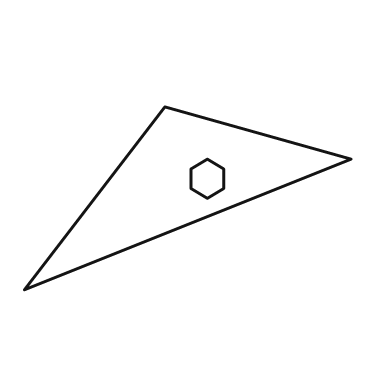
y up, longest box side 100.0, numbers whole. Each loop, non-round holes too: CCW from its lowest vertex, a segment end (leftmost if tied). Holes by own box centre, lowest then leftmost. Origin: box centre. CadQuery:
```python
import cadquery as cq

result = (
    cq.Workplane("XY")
    .moveTo(-50.0, -28.0)
    .lineTo(50.0, 12.0)
    .lineTo(-7.0, 28.0)
    .close()
    .moveTo(6.0, 0.0)
    .lineTo(11.0, 3.0)
    .lineTo(11.0, 9.0)
    .lineTo(6.0, 12.0)
    .lineTo(1.0, 9.0)
    .lineTo(1.0, 3.0)
    .close()
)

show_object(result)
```